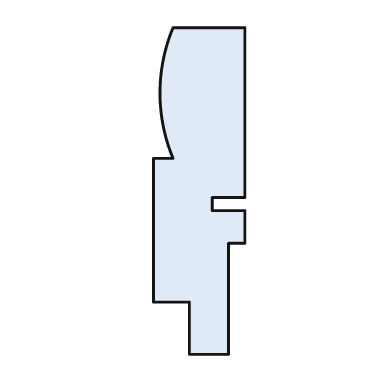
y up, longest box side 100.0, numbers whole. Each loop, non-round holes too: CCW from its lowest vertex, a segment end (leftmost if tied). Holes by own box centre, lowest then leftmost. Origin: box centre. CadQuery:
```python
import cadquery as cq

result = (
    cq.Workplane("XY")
    .moveTo(-3.0, -50.0)
    .lineTo(9.0, -50.0)
    .lineTo(9.0, -16.0)
    .lineTo(14.0, -16.0)
    .lineTo(14.0, -6.0)
    .lineTo(4.0, -6.0)
    .lineTo(4.0, -2.0)
    .lineTo(14.0, -2.0)
    .lineTo(14.0, 50.0)
    .lineTo(-8.0, 50.0)
    .threePointArc((-12.0, 30.0), (-8.0, 10.0))
    .lineTo(-14.0, 10.0)
    .lineTo(-14.0, -34.0)
    .lineTo(-3.0, -34.0)
    .close()
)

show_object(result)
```